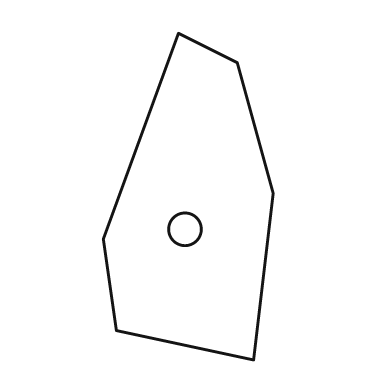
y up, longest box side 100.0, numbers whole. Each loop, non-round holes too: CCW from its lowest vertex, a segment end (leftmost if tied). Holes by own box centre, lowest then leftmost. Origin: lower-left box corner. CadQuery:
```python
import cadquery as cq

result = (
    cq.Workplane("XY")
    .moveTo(46.0, 0.0)
    .lineTo(52.0, 51.0)
    .lineTo(41.0, 91.0)
    .lineTo(23.0, 100.0)
    .lineTo(0.0, 37.0)
    .lineTo(4.0, 9.0)
    .close()
    .moveTo(25.0, 40.0)
    .circle(5.0)
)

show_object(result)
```